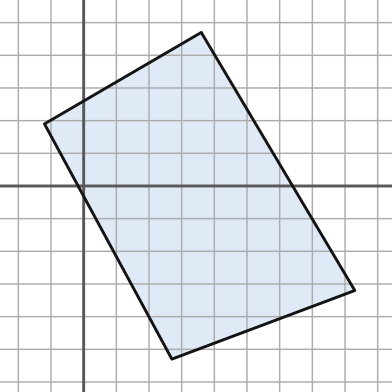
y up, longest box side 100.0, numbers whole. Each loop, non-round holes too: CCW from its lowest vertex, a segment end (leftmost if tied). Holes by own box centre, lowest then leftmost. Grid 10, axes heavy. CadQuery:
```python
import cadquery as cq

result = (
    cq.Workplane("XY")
    .moveTo(27.0, -53.0)
    .lineTo(83.0, -32.0)
    .lineTo(36.0, 47.0)
    .lineTo(-12.0, 19.0)
    .close()
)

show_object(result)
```